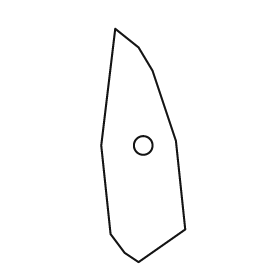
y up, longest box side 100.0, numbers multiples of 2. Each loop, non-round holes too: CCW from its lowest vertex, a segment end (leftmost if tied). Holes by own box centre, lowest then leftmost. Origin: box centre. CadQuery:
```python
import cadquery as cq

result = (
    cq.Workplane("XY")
    .moveTo(-2.0, -50.0)
    .lineTo(18.0, -36.0)
    .lineTo(14.0, 2.0)
    .lineTo(4.0, 32.0)
    .lineTo(-2.0, 42.0)
    .lineTo(-12.0, 50.0)
    .lineTo(-18.0, 0.0)
    .lineTo(-14.0, -38.0)
    .lineTo(-8.0, -46.0)
    .close()
    .moveTo(0.0, 0.0)
    .circle(4.0)
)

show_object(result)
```